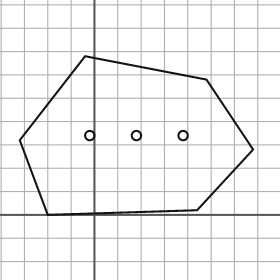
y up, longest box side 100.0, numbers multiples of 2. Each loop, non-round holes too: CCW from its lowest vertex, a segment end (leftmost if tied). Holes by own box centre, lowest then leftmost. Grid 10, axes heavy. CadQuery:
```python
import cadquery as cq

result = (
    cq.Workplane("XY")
    .moveTo(-20.0, 0.0)
    .lineTo(44.0, 2.0)
    .lineTo(68.0, 28.0)
    .lineTo(48.0, 58.0)
    .lineTo(-4.0, 68.0)
    .lineTo(-32.0, 32.0)
    .close()
    .moveTo(-2.0, 34.0)
    .circle(2.0)
    .moveTo(18.0, 34.0)
    .circle(2.0)
    .moveTo(38.0, 34.0)
    .circle(2.0)
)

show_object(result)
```